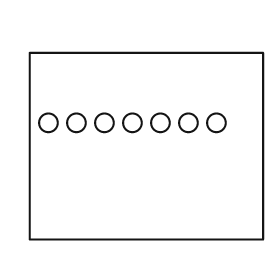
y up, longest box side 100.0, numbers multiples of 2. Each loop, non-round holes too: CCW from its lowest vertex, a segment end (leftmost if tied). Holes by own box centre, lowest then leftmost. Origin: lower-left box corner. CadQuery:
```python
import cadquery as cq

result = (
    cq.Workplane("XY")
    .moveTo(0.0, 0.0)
    .lineTo(100.0, 0.0)
    .lineTo(100.0, 80.0)
    .lineTo(0.0, 80.0)
    .close()
    .moveTo(8.0, 50.0)
    .circle(4.0)
    .moveTo(20.0, 50.0)
    .circle(4.0)
    .moveTo(32.0, 50.0)
    .circle(4.0)
    .moveTo(44.0, 50.0)
    .circle(4.0)
    .moveTo(56.0, 50.0)
    .circle(4.0)
    .moveTo(68.0, 50.0)
    .circle(4.0)
    .moveTo(80.0, 50.0)
    .circle(4.0)
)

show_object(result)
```